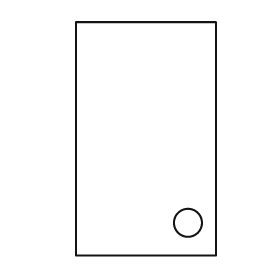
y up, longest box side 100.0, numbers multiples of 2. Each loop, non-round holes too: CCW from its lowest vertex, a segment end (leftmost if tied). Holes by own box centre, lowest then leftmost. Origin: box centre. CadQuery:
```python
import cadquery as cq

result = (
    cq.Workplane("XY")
    .moveTo(-30.0, -50.0)
    .lineTo(30.0, -50.0)
    .lineTo(30.0, 50.0)
    .lineTo(-30.0, 50.0)
    .close()
    .moveTo(18.0, -36.0)
    .circle(6.0)
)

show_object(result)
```